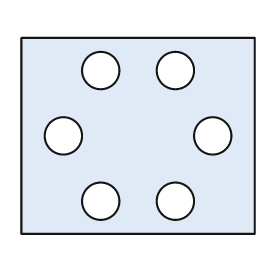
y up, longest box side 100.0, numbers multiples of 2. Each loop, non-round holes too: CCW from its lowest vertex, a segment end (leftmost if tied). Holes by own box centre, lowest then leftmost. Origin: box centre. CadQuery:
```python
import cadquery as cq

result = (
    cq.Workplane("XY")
    .moveTo(-50.0, -42.0)
    .lineTo(50.0, -42.0)
    .lineTo(50.0, 42.0)
    .lineTo(-50.0, 42.0)
    .close()
    .moveTo(-16.0, -28.0)
    .circle(8.0)
    .moveTo(16.0, -28.0)
    .circle(8.0)
    .moveTo(-32.0, 0.0)
    .circle(8.0)
    .moveTo(32.0, 0.0)
    .circle(8.0)
    .moveTo(-16.0, 28.0)
    .circle(8.0)
    .moveTo(16.0, 28.0)
    .circle(8.0)
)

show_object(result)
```